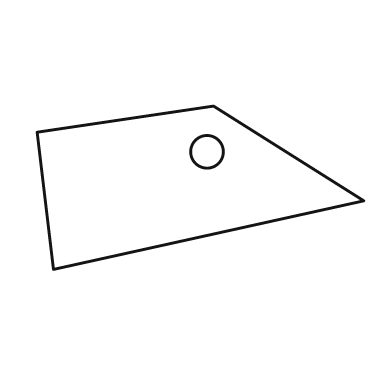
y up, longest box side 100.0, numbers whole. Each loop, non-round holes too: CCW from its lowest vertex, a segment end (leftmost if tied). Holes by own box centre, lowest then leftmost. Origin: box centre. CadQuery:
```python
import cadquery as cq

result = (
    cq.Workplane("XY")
    .moveTo(-45.0, -25.0)
    .lineTo(50.0, -4.0)
    .lineTo(4.0, 25.0)
    .lineTo(-50.0, 17.0)
    .close()
    .moveTo(2.0, 11.0)
    .circle(5.0)
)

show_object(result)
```